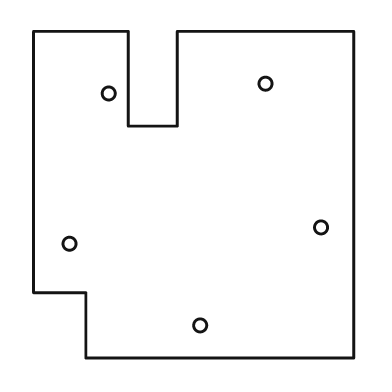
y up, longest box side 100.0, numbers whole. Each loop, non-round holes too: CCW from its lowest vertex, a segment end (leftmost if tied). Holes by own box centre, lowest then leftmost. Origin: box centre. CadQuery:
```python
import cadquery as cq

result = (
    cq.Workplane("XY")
    .moveTo(-33.0, -50.0)
    .lineTo(49.0, -50.0)
    .lineTo(49.0, 50.0)
    .lineTo(-5.0, 50.0)
    .lineTo(-5.0, 21.0)
    .lineTo(-20.0, 21.0)
    .lineTo(-20.0, 50.0)
    .lineTo(-49.0, 50.0)
    .lineTo(-49.0, -30.0)
    .lineTo(-33.0, -30.0)
    .close()
    .moveTo(2.0, -40.0)
    .circle(2.0)
    .moveTo(-38.0, -15.0)
    .circle(2.0)
    .moveTo(39.0, -10.0)
    .circle(2.0)
    .moveTo(-26.0, 31.0)
    .circle(2.0)
    .moveTo(22.0, 34.0)
    .circle(2.0)
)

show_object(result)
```